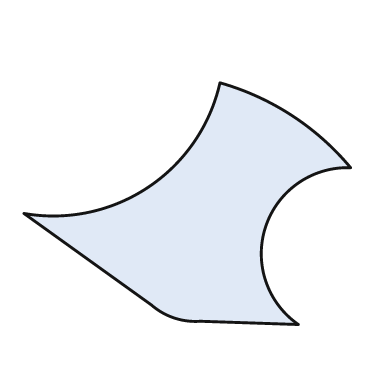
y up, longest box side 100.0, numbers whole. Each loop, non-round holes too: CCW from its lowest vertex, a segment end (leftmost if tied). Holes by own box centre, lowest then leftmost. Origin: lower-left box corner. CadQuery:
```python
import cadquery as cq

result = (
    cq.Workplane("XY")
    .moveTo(84.0, 0.0)
    .threePointArc((74.0, 30.0), (100.0, 48.0))
    .threePointArc((82.0, 64.0), (60.0, 74.0))
    .threePointArc((38.0, 42.0), (0.0, 34.0))
    .lineTo(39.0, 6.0)
    .threePointArc((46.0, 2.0), (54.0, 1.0))
    .close()
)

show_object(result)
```